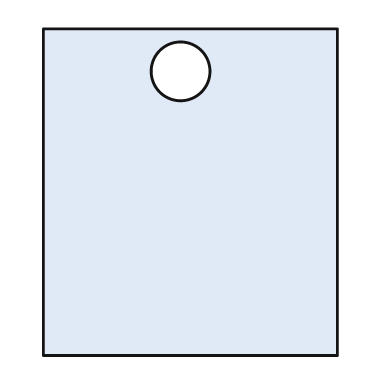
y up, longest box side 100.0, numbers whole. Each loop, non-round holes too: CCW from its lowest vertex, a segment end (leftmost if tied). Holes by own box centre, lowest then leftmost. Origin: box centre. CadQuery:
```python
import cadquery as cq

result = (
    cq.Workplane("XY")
    .moveTo(-45.0, -50.0)
    .lineTo(45.0, -50.0)
    .lineTo(45.0, 50.0)
    .lineTo(-45.0, 50.0)
    .close()
    .moveTo(-3.0, 37.0)
    .circle(9.0)
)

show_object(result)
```